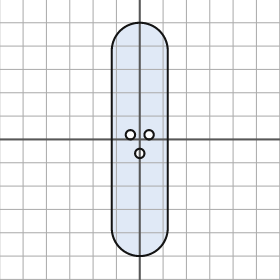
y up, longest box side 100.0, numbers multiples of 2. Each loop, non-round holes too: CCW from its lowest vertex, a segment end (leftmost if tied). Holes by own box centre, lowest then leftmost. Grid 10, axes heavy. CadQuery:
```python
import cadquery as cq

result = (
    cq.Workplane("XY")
    .moveTo(-12.0, -38.0)
    .threePointArc((0.0, -50.0), (12.0, -38.0))
    .lineTo(12.0, 38.0)
    .threePointArc((0.0, 50.0), (-12.0, 38.0))
    .close()
    .moveTo(0.0, -6.0)
    .circle(2.0)
    .moveTo(-4.0, 2.0)
    .circle(2.0)
    .moveTo(4.0, 2.0)
    .circle(2.0)
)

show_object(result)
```